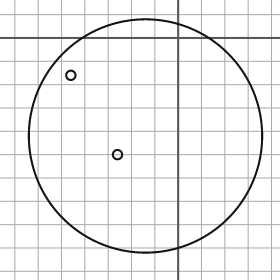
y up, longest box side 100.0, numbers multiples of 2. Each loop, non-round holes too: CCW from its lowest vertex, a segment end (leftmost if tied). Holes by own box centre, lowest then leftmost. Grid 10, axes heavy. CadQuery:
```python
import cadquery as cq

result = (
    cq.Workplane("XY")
    .moveTo(-14.0, -42.0)
    .circle(50.0)
    .moveTo(-26.0, -50.0)
    .circle(2.0)
    .moveTo(-46.0, -16.0)
    .circle(2.0)
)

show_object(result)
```